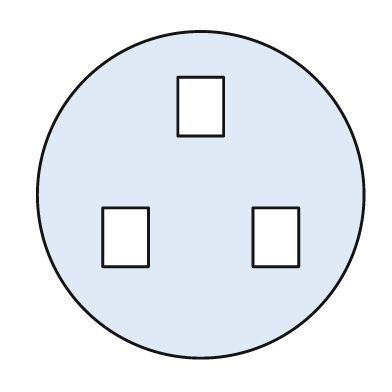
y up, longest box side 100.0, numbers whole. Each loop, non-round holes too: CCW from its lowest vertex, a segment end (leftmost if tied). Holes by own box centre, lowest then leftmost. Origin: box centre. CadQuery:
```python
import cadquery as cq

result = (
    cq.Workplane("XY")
    .moveTo(0.0, 0.0)
    .circle(50.0)
    .moveTo(-30.0, -22.0)
    .lineTo(-16.0, -22.0)
    .lineTo(-16.0, -4.0)
    .lineTo(-30.0, -4.0)
    .close()
    .moveTo(16.0, -22.0)
    .lineTo(30.0, -22.0)
    .lineTo(30.0, -4.0)
    .lineTo(16.0, -4.0)
    .close()
    .moveTo(-7.0, 18.0)
    .lineTo(7.0, 18.0)
    .lineTo(7.0, 36.0)
    .lineTo(-7.0, 36.0)
    .close()
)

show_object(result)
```